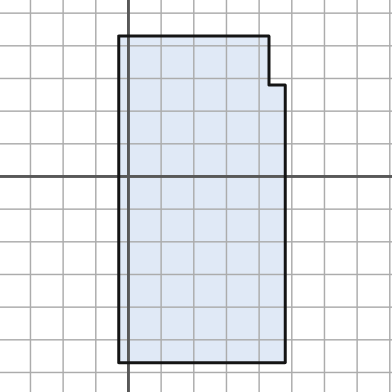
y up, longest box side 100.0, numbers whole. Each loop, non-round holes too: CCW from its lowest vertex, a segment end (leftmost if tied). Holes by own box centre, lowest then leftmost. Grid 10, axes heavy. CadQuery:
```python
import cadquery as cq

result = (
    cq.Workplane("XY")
    .moveTo(-3.0, -57.0)
    .lineTo(48.0, -57.0)
    .lineTo(48.0, 28.0)
    .lineTo(43.0, 28.0)
    .lineTo(43.0, 43.0)
    .lineTo(-3.0, 43.0)
    .close()
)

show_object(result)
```